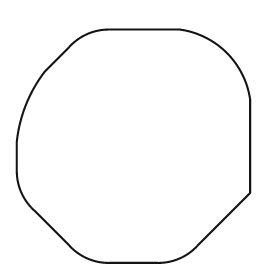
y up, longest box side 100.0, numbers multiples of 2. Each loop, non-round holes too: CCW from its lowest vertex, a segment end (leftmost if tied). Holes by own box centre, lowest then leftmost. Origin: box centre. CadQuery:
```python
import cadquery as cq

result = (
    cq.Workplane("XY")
    .moveTo(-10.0, -50.0)
    .lineTo(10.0, -50.0)
    .threePointArc((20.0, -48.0), (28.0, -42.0))
    .lineTo(50.0, -20.0)
    .lineTo(50.0, 20.0)
    .threePointArc((40.0, 40.0), (20.0, 50.0))
    .lineTo(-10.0, 50.0)
    .threePointArc((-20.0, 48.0), (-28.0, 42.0))
    .lineTo(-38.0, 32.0)
    .threePointArc((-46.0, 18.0), (-50.0, 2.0))
    .lineTo(-50.0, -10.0)
    .threePointArc((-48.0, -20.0), (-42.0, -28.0))
    .lineTo(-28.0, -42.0)
    .threePointArc((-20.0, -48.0), (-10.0, -50.0))
    .close()
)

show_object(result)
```